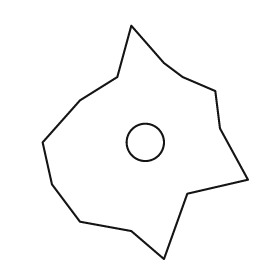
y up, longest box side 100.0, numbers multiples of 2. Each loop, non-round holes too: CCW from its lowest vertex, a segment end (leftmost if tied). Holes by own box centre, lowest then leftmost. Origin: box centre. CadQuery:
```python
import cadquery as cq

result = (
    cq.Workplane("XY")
    .moveTo(8.0, -50.0)
    .lineTo(18.0, -22.0)
    .lineTo(44.0, -16.0)
    .lineTo(32.0, 6.0)
    .lineTo(30.0, 22.0)
    .lineTo(16.0, 28.0)
    .lineTo(8.0, 34.0)
    .lineTo(-6.0, 50.0)
    .lineTo(-12.0, 28.0)
    .lineTo(-28.0, 18.0)
    .lineTo(-44.0, 0.0)
    .lineTo(-40.0, -18.0)
    .lineTo(-28.0, -34.0)
    .lineTo(-6.0, -38.0)
    .close()
    .moveTo(0.0, 0.0)
    .circle(8.0)
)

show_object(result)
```